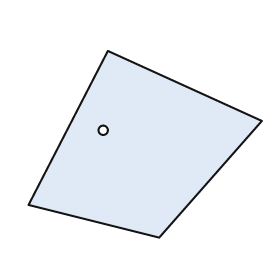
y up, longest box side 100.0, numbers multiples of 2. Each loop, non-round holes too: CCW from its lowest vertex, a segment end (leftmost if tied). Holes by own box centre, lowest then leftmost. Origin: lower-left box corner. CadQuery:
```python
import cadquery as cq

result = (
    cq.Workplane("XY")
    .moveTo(56.0, 0.0)
    .lineTo(100.0, 50.0)
    .lineTo(34.0, 80.0)
    .lineTo(0.0, 14.0)
    .close()
    .moveTo(32.0, 46.0)
    .circle(2.0)
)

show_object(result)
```